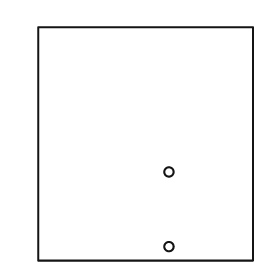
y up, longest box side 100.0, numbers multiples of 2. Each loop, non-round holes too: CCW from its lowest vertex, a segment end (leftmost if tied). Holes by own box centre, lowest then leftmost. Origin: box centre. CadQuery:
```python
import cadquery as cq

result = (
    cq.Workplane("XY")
    .moveTo(-46.0, -50.0)
    .lineTo(46.0, -50.0)
    .lineTo(46.0, 50.0)
    .lineTo(-46.0, 50.0)
    .close()
    .moveTo(10.0, -44.0)
    .circle(2.0)
    .moveTo(10.0, -12.0)
    .circle(2.0)
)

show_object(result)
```